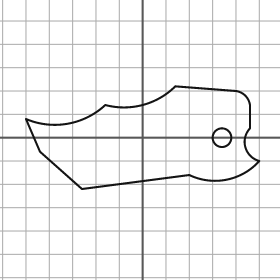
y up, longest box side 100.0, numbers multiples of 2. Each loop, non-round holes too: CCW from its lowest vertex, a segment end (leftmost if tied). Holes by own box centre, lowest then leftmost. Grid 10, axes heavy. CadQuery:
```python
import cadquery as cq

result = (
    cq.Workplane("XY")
    .moveTo(-26.0, -22.0)
    .lineTo(20.0, -16.0)
    .threePointArc((36.0, -18.0), (50.0, -10.0))
    .threePointArc((44.0, -4.0), (46.0, 4.0))
    .lineTo(46.0, 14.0)
    .threePointArc((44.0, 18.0), (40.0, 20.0))
    .lineTo(14.0, 22.0)
    .threePointArc((0.0, 14.0), (-16.0, 14.0))
    .threePointArc((-32.0, 6.0), (-50.0, 8.0))
    .lineTo(-44.0, -6.0)
    .close()
    .moveTo(34.0, 0.0)
    .circle(4.0)
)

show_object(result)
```